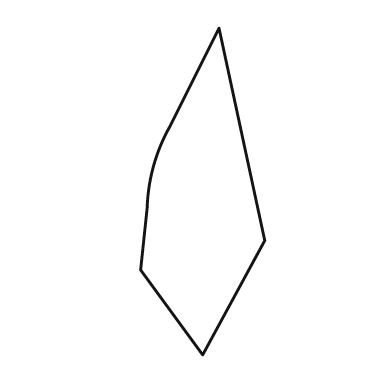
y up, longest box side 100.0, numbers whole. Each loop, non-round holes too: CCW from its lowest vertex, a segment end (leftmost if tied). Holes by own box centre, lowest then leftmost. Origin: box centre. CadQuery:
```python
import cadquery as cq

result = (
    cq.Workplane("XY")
    .moveTo(0.0, -50.0)
    .lineTo(19.0, -15.0)
    .lineTo(5.0, 50.0)
    .lineTo(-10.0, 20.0)
    .threePointArc((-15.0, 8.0), (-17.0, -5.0))
    .lineTo(-19.0, -24.0)
    .close()
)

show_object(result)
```